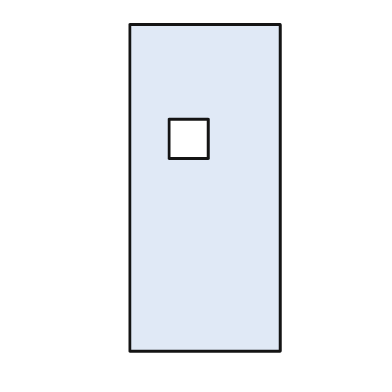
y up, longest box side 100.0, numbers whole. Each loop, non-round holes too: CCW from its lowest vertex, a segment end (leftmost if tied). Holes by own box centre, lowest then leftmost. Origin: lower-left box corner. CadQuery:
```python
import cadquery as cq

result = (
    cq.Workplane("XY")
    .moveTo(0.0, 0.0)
    .lineTo(46.0, 0.0)
    .lineTo(46.0, 100.0)
    .lineTo(0.0, 100.0)
    .close()
    .moveTo(12.0, 59.0)
    .lineTo(24.0, 59.0)
    .lineTo(24.0, 71.0)
    .lineTo(12.0, 71.0)
    .close()
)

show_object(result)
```